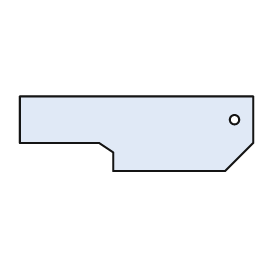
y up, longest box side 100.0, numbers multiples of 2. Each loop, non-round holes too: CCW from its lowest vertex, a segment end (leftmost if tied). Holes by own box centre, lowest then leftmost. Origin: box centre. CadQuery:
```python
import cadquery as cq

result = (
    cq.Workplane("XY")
    .moveTo(-10.0, -16.0)
    .lineTo(38.0, -16.0)
    .lineTo(50.0, -4.0)
    .lineTo(50.0, 16.0)
    .lineTo(-50.0, 16.0)
    .lineTo(-50.0, -4.0)
    .lineTo(-16.0, -4.0)
    .lineTo(-10.0, -8.0)
    .close()
    .moveTo(42.0, 6.0)
    .circle(2.0)
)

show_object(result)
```